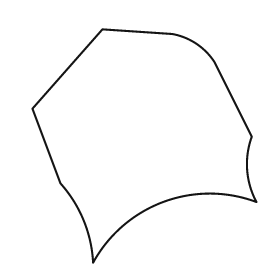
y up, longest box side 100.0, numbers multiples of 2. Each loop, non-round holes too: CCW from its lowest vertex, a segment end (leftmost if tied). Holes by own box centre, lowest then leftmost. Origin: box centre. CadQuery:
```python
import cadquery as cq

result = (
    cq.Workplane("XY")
    .moveTo(-22.0, -50.0)
    .threePointArc((8.0, -24.0), (48.0, -24.0))
    .threePointArc((44.0, -10.0), (46.0, 4.0))
    .lineTo(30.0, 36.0)
    .threePointArc((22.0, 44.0), (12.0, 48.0))
    .lineTo(-18.0, 50.0)
    .lineTo(-48.0, 16.0)
    .lineTo(-36.0, -16.0)
    .threePointArc((-26.0, -32.0), (-22.0, -50.0))
    .close()
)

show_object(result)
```